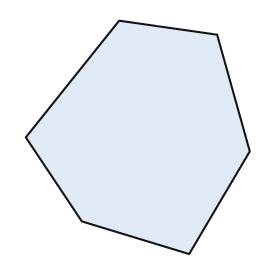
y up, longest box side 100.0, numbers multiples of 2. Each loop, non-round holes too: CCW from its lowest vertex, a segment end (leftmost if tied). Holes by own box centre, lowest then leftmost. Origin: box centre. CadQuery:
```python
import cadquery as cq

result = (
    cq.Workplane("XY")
    .moveTo(22.0, -50.0)
    .lineTo(48.0, -6.0)
    .lineTo(34.0, 44.0)
    .lineTo(-8.0, 50.0)
    .lineTo(-48.0, 0.0)
    .lineTo(-24.0, -36.0)
    .close()
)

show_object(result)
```